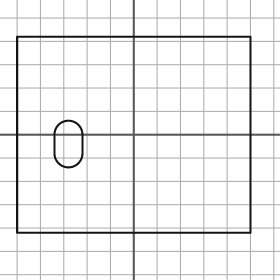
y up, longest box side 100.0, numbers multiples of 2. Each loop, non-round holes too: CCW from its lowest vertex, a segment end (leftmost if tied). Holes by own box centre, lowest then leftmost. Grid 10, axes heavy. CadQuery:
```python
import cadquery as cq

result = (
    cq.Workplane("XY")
    .moveTo(-50.0, -42.0)
    .lineTo(50.0, -42.0)
    .lineTo(50.0, 42.0)
    .lineTo(-50.0, 42.0)
    .close()
    .moveTo(-34.0, -8.0)
    .threePointArc((-28.0, -14.0), (-22.0, -8.0))
    .lineTo(-22.0, 0.0)
    .threePointArc((-28.0, 6.0), (-34.0, 0.0))
    .close()
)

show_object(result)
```